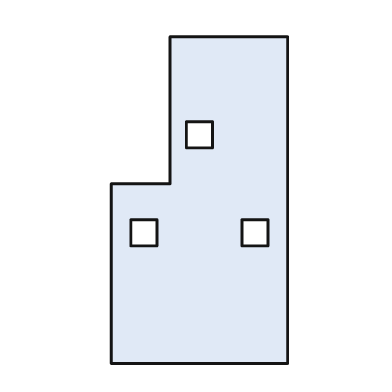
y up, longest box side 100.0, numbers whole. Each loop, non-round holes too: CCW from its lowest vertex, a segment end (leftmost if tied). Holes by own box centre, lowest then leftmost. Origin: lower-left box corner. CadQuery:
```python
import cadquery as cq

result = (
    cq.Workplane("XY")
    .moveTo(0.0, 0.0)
    .lineTo(54.0, 0.0)
    .lineTo(54.0, 100.0)
    .lineTo(18.0, 100.0)
    .lineTo(18.0, 55.0)
    .lineTo(0.0, 55.0)
    .close()
    .moveTo(6.0, 36.0)
    .lineTo(14.0, 36.0)
    .lineTo(14.0, 44.0)
    .lineTo(6.0, 44.0)
    .close()
    .moveTo(40.0, 36.0)
    .lineTo(48.0, 36.0)
    .lineTo(48.0, 44.0)
    .lineTo(40.0, 44.0)
    .close()
    .moveTo(23.0, 66.0)
    .lineTo(31.0, 66.0)
    .lineTo(31.0, 74.0)
    .lineTo(23.0, 74.0)
    .close()
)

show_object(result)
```